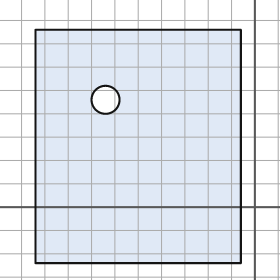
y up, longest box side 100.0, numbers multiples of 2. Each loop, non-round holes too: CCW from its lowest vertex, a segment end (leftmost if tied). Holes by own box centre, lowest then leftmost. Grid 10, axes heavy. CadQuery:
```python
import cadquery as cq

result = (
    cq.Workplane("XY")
    .moveTo(-94.0, -24.0)
    .lineTo(-6.0, -24.0)
    .lineTo(-6.0, 76.0)
    .lineTo(-94.0, 76.0)
    .close()
    .moveTo(-64.0, 46.0)
    .circle(6.0)
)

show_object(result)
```